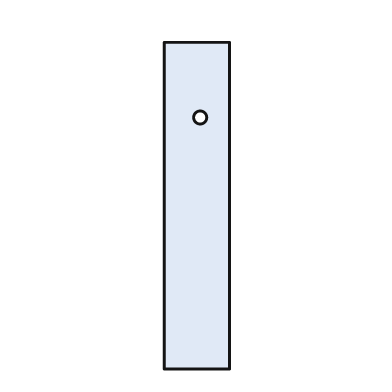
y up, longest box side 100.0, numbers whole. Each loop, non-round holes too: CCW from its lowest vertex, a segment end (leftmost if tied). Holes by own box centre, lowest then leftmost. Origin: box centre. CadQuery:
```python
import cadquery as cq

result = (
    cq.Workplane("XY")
    .moveTo(-10.0, -50.0)
    .lineTo(10.0, -50.0)
    .lineTo(10.0, 50.0)
    .lineTo(-10.0, 50.0)
    .close()
    .moveTo(1.0, 27.0)
    .circle(2.0)
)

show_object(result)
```